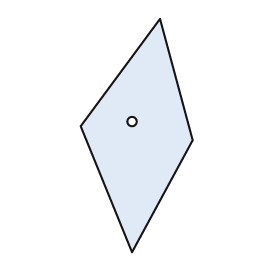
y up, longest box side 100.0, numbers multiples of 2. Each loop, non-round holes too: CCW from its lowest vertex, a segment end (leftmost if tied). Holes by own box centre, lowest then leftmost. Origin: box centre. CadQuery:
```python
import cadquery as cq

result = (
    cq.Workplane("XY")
    .moveTo(-2.0, -50.0)
    .lineTo(24.0, -2.0)
    .lineTo(10.0, 50.0)
    .lineTo(-24.0, 4.0)
    .close()
    .moveTo(-2.0, 6.0)
    .circle(2.0)
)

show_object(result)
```